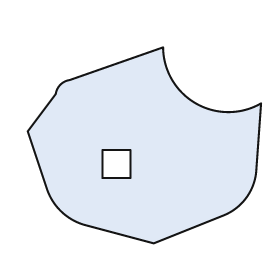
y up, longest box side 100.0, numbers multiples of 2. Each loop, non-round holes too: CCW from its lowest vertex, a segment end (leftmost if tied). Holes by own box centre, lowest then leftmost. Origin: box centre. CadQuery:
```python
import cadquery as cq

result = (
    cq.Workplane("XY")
    .moveTo(4.0, -42.0)
    .lineTo(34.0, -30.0)
    .threePointArc((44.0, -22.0), (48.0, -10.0))
    .lineTo(50.0, 18.0)
    .threePointArc((22.0, 18.0), (8.0, 42.0))
    .lineTo(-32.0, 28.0)
    .threePointArc((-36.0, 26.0), (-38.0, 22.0))
    .lineTo(-50.0, 6.0)
    .lineTo(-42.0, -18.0)
    .threePointArc((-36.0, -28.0), (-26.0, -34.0))
    .close()
    .moveTo(-18.0, -14.0)
    .lineTo(-6.0, -14.0)
    .lineTo(-6.0, -2.0)
    .lineTo(-18.0, -2.0)
    .close()
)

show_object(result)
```